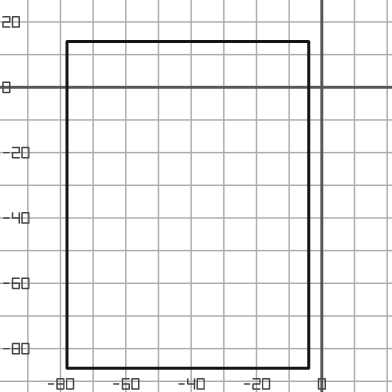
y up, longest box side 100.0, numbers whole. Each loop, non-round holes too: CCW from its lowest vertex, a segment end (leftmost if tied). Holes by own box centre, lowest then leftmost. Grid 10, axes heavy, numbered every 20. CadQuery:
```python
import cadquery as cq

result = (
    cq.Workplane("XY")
    .moveTo(-78.0, -86.0)
    .lineTo(-4.0, -86.0)
    .lineTo(-4.0, 14.0)
    .lineTo(-78.0, 14.0)
    .close()
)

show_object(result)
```